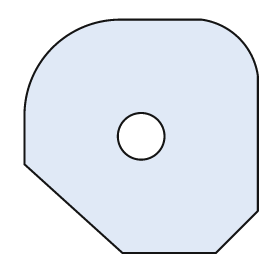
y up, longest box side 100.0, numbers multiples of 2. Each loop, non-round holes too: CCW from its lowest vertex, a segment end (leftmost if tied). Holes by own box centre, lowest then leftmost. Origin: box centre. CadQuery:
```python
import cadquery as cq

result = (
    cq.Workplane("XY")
    .moveTo(-8.0, -50.0)
    .lineTo(32.0, -50.0)
    .lineTo(50.0, -32.0)
    .lineTo(50.0, 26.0)
    .threePointArc((42.0, 42.0), (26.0, 50.0))
    .lineTo(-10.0, 50.0)
    .threePointArc((-38.0, 38.0), (-50.0, 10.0))
    .lineTo(-50.0, -12.0)
    .close()
    .moveTo(0.0, 0.0)
    .circle(10.0)
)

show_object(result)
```